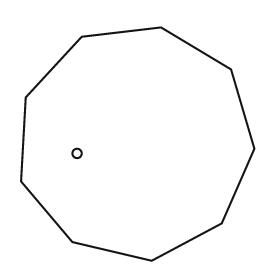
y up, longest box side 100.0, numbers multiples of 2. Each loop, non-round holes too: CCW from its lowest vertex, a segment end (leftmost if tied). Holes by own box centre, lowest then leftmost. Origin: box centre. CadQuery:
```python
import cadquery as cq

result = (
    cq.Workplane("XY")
    .moveTo(6.0, -50.0)
    .lineTo(36.0, -34.0)
    .lineTo(50.0, -2.0)
    .lineTo(40.0, 32.0)
    .lineTo(10.0, 50.0)
    .lineTo(-24.0, 46.0)
    .lineTo(-48.0, 20.0)
    .lineTo(-50.0, -16.0)
    .lineTo(-28.0, -42.0)
    .close()
    .moveTo(-26.0, -4.0)
    .circle(2.0)
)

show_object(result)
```